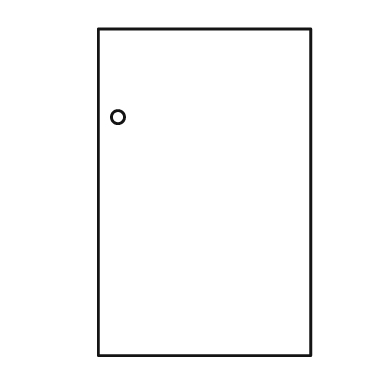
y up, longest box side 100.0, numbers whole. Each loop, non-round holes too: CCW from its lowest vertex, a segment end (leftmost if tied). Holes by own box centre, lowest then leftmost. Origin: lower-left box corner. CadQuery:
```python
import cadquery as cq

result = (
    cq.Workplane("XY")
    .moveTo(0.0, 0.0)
    .lineTo(65.0, 0.0)
    .lineTo(65.0, 100.0)
    .lineTo(0.0, 100.0)
    .close()
    .moveTo(6.0, 73.0)
    .circle(2.0)
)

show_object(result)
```